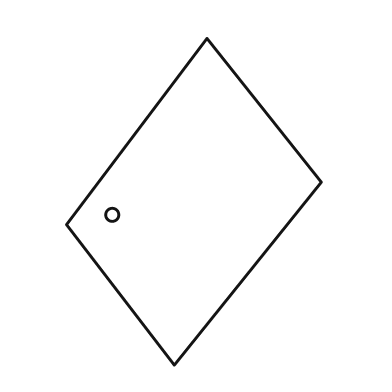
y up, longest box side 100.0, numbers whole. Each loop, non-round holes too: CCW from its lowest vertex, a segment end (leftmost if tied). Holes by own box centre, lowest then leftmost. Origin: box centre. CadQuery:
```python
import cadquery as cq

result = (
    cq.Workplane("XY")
    .moveTo(-6.0, -50.0)
    .lineTo(39.0, 6.0)
    .lineTo(4.0, 50.0)
    .lineTo(-39.0, -7.0)
    .close()
    .moveTo(-25.0, -4.0)
    .circle(2.0)
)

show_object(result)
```